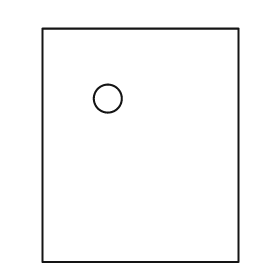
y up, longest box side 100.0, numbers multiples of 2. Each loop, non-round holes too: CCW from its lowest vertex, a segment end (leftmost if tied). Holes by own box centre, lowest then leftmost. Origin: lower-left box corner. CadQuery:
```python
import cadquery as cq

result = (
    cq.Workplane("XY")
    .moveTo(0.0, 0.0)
    .lineTo(84.0, 0.0)
    .lineTo(84.0, 100.0)
    .lineTo(0.0, 100.0)
    .close()
    .moveTo(28.0, 70.0)
    .circle(6.0)
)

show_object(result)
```